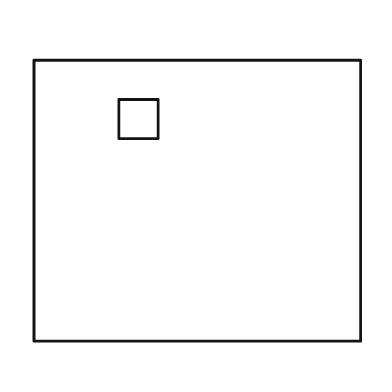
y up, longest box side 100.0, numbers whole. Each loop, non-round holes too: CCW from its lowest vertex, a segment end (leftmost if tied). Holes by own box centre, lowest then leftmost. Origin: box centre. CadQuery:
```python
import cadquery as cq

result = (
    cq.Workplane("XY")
    .moveTo(-50.0, -43.0)
    .lineTo(50.0, -43.0)
    .lineTo(50.0, 43.0)
    .lineTo(-50.0, 43.0)
    .close()
    .moveTo(-24.0, 19.0)
    .lineTo(-12.0, 19.0)
    .lineTo(-12.0, 31.0)
    .lineTo(-24.0, 31.0)
    .close()
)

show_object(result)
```